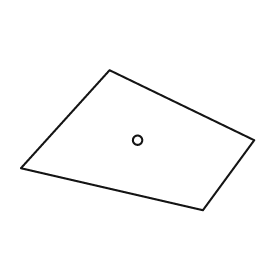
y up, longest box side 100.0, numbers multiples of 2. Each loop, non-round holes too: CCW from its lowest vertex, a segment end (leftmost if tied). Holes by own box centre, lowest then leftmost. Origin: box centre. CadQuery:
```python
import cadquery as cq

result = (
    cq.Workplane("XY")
    .moveTo(28.0, -30.0)
    .lineTo(50.0, 0.0)
    .lineTo(-12.0, 30.0)
    .lineTo(-50.0, -12.0)
    .close()
    .moveTo(0.0, 0.0)
    .circle(2.0)
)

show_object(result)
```